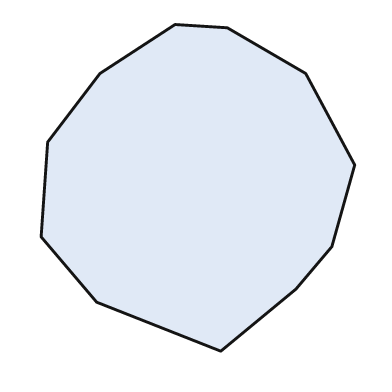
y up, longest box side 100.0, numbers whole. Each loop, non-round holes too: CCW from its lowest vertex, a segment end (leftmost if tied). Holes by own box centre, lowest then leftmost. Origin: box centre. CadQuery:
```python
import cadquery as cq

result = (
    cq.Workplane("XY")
    .moveTo(7.0, -50.0)
    .lineTo(30.0, -31.0)
    .lineTo(41.0, -18.0)
    .lineTo(48.0, 7.0)
    .lineTo(33.0, 35.0)
    .lineTo(9.0, 49.0)
    .lineTo(-7.0, 50.0)
    .lineTo(-30.0, 35.0)
    .lineTo(-46.0, 14.0)
    .lineTo(-48.0, -15.0)
    .lineTo(-31.0, -35.0)
    .close()
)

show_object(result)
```